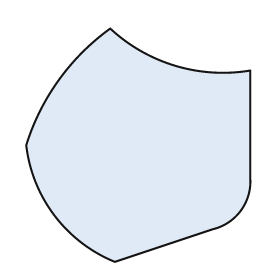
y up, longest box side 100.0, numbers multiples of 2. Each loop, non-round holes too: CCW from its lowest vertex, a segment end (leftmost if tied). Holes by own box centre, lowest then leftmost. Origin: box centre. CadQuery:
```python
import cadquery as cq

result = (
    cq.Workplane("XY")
    .moveTo(-10.0, -50.0)
    .lineTo(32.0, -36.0)
    .threePointArc((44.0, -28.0), (48.0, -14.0))
    .lineTo(48.0, 32.0)
    .threePointArc((16.0, 34.0), (-12.0, 50.0))
    .threePointArc((-34.0, 28.0), (-48.0, 0.0))
    .threePointArc((-36.0, -30.0), (-10.0, -50.0))
    .close()
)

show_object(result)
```